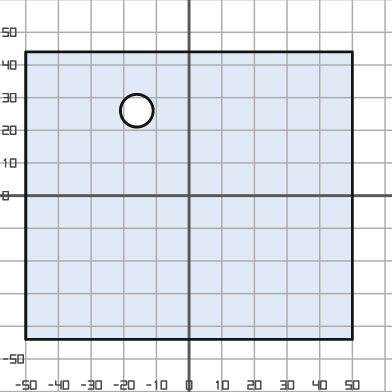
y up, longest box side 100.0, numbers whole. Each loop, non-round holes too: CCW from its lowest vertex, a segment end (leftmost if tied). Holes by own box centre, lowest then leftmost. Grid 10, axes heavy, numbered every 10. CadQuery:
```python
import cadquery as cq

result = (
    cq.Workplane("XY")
    .moveTo(-50.0, -44.0)
    .lineTo(50.0, -44.0)
    .lineTo(50.0, 44.0)
    .lineTo(-50.0, 44.0)
    .close()
    .moveTo(-16.0, 26.0)
    .circle(5.0)
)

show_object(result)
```